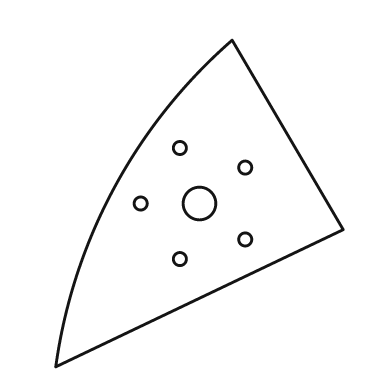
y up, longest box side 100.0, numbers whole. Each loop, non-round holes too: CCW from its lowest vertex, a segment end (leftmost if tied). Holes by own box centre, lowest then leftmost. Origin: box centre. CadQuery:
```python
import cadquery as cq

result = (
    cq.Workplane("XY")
    .moveTo(-44.0, -50.0)
    .lineTo(44.0, -8.0)
    .lineTo(10.0, 50.0)
    .threePointArc((-26.0, 5.0), (-44.0, -50.0))
    .close()
    .moveTo(-6.0, -17.0)
    .circle(2.0)
    .moveTo(14.0, -11.0)
    .circle(2.0)
    .moveTo(-18.0, 0.0)
    .circle(2.0)
    .moveTo(0.0, 0.0)
    .circle(5.0)
    .moveTo(14.0, 11.0)
    .circle(2.0)
    .moveTo(-6.0, 17.0)
    .circle(2.0)
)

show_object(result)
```